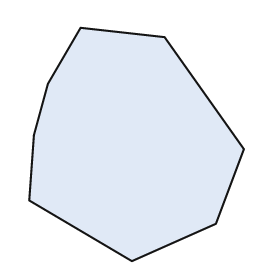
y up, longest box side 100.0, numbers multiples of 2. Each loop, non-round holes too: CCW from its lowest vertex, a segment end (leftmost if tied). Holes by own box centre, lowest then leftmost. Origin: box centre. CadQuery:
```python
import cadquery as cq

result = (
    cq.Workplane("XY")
    .moveTo(-2.0, -50.0)
    .lineTo(34.0, -34.0)
    .lineTo(46.0, -2.0)
    .lineTo(12.0, 46.0)
    .lineTo(-24.0, 50.0)
    .lineTo(-38.0, 26.0)
    .lineTo(-44.0, 4.0)
    .lineTo(-46.0, -24.0)
    .close()
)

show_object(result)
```